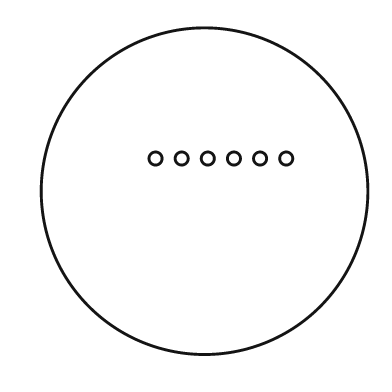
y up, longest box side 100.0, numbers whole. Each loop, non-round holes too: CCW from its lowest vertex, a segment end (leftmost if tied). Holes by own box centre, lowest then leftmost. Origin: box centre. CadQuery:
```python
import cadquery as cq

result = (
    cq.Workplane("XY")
    .moveTo(0.0, 0.0)
    .circle(50.0)
    .moveTo(-15.0, 10.0)
    .circle(2.0)
    .moveTo(-7.0, 10.0)
    .circle(2.0)
    .moveTo(1.0, 10.0)
    .circle(2.0)
    .moveTo(9.0, 10.0)
    .circle(2.0)
    .moveTo(17.0, 10.0)
    .circle(2.0)
    .moveTo(25.0, 10.0)
    .circle(2.0)
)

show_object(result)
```